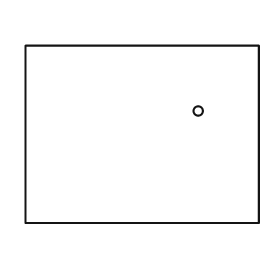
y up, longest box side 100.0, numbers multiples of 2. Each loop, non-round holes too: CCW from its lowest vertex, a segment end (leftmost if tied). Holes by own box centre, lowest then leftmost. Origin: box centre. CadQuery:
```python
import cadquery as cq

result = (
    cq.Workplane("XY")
    .moveTo(-50.0, -38.0)
    .lineTo(50.0, -38.0)
    .lineTo(50.0, 38.0)
    .lineTo(-50.0, 38.0)
    .close()
    .moveTo(24.0, 10.0)
    .circle(2.0)
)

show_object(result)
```